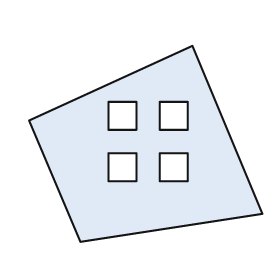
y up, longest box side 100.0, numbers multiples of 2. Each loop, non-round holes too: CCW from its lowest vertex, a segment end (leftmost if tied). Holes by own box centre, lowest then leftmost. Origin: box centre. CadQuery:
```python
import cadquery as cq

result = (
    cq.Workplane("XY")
    .moveTo(-28.0, -42.0)
    .lineTo(50.0, -30.0)
    .lineTo(20.0, 42.0)
    .lineTo(-50.0, 10.0)
    .close()
    .moveTo(-16.0, -16.0)
    .lineTo(-4.0, -16.0)
    .lineTo(-4.0, -4.0)
    .lineTo(-16.0, -4.0)
    .close()
    .moveTo(6.0, -16.0)
    .lineTo(18.0, -16.0)
    .lineTo(18.0, -4.0)
    .lineTo(6.0, -4.0)
    .close()
    .moveTo(-16.0, 6.0)
    .lineTo(-4.0, 6.0)
    .lineTo(-4.0, 18.0)
    .lineTo(-16.0, 18.0)
    .close()
    .moveTo(6.0, 6.0)
    .lineTo(18.0, 6.0)
    .lineTo(18.0, 18.0)
    .lineTo(6.0, 18.0)
    .close()
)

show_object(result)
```